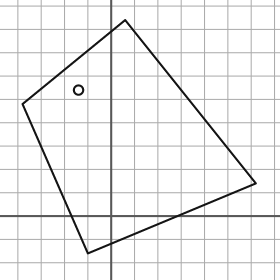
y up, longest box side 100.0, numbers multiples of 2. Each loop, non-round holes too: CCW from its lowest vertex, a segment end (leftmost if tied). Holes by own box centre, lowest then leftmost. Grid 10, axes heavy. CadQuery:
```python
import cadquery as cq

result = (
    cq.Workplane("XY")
    .moveTo(-10.0, -16.0)
    .lineTo(62.0, 14.0)
    .lineTo(6.0, 84.0)
    .lineTo(-38.0, 48.0)
    .close()
    .moveTo(-14.0, 54.0)
    .circle(2.0)
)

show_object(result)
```